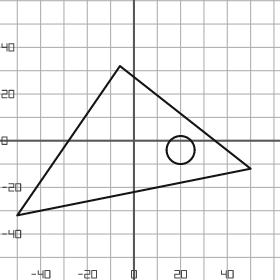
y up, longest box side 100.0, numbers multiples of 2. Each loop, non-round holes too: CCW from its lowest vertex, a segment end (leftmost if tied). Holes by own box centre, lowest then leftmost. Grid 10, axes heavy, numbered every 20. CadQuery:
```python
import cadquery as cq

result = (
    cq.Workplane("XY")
    .moveTo(-50.0, -32.0)
    .lineTo(50.0, -12.0)
    .lineTo(-6.0, 32.0)
    .close()
    .moveTo(20.0, -4.0)
    .circle(6.0)
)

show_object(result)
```